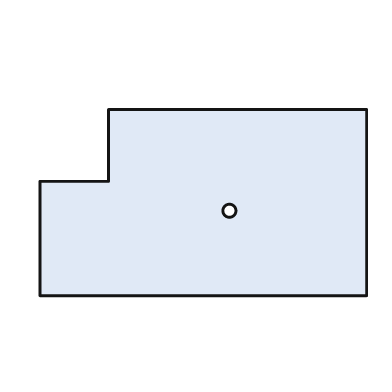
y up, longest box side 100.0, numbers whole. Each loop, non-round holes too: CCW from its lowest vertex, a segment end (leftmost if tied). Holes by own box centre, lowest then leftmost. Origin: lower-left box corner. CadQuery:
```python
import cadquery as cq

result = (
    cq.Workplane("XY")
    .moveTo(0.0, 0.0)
    .lineTo(100.0, 0.0)
    .lineTo(100.0, 57.0)
    .lineTo(21.0, 57.0)
    .lineTo(21.0, 35.0)
    .lineTo(0.0, 35.0)
    .close()
    .moveTo(58.0, 26.0)
    .circle(2.0)
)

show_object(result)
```